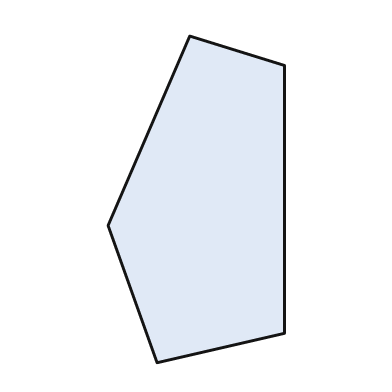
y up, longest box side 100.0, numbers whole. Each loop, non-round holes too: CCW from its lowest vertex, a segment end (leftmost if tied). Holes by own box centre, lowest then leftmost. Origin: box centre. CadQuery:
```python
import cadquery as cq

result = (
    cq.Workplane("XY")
    .moveTo(-12.0, -50.0)
    .lineTo(27.0, -41.0)
    .lineTo(27.0, 41.0)
    .lineTo(-2.0, 50.0)
    .lineTo(-27.0, -8.0)
    .close()
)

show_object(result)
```